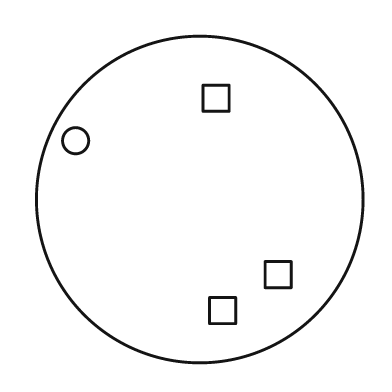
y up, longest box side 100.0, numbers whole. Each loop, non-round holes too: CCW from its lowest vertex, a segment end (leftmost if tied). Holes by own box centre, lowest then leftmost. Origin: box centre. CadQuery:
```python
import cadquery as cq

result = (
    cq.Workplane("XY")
    .moveTo(0.0, 0.0)
    .circle(50.0)
    .moveTo(3.0, -38.0)
    .lineTo(11.0, -38.0)
    .lineTo(11.0, -30.0)
    .lineTo(3.0, -30.0)
    .close()
    .moveTo(20.0, -27.0)
    .lineTo(28.0, -27.0)
    .lineTo(28.0, -19.0)
    .lineTo(20.0, -19.0)
    .close()
    .moveTo(-38.0, 18.0)
    .circle(4.0)
    .moveTo(1.0, 27.0)
    .lineTo(9.0, 27.0)
    .lineTo(9.0, 35.0)
    .lineTo(1.0, 35.0)
    .close()
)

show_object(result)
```